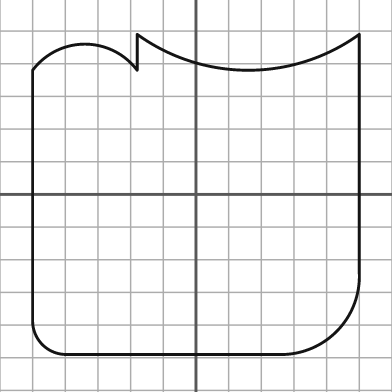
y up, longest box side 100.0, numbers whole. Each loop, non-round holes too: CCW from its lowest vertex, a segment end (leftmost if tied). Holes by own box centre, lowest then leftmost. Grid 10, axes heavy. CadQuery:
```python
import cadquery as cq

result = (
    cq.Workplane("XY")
    .moveTo(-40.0, -49.0)
    .lineTo(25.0, -49.0)
    .threePointArc((43.0, -42.0), (50.0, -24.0))
    .lineTo(50.0, 49.0)
    .threePointArc((16.0, 38.0), (-18.0, 49.0))
    .lineTo(-18.0, 38.0)
    .threePointArc((-34.0, 46.0), (-50.0, 38.0))
    .lineTo(-50.0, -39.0)
    .threePointArc((-47.0, -46.0), (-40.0, -49.0))
    .close()
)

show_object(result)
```